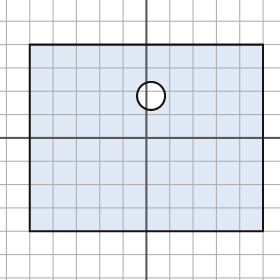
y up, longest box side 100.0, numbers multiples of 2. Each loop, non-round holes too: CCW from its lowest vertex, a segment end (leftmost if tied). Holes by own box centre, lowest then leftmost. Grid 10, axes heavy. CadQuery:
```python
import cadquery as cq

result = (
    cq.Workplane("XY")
    .moveTo(-50.0, -40.0)
    .lineTo(50.0, -40.0)
    .lineTo(50.0, 40.0)
    .lineTo(-50.0, 40.0)
    .close()
    .moveTo(2.0, 18.0)
    .circle(6.0)
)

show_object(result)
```